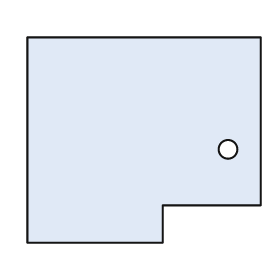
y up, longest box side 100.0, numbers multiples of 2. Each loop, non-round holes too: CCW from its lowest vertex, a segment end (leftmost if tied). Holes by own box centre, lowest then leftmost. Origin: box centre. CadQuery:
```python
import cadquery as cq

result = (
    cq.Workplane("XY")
    .moveTo(-50.0, -44.0)
    .lineTo(8.0, -44.0)
    .lineTo(8.0, -28.0)
    .lineTo(50.0, -28.0)
    .lineTo(50.0, 44.0)
    .lineTo(-50.0, 44.0)
    .close()
    .moveTo(36.0, -4.0)
    .circle(4.0)
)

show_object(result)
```